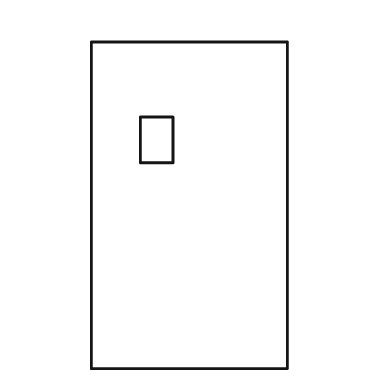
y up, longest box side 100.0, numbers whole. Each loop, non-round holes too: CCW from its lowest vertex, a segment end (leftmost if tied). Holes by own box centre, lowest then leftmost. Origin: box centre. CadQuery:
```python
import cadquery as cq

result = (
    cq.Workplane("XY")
    .moveTo(-30.0, -50.0)
    .lineTo(30.0, -50.0)
    .lineTo(30.0, 50.0)
    .lineTo(-30.0, 50.0)
    .close()
    .moveTo(-15.0, 13.0)
    .lineTo(-5.0, 13.0)
    .lineTo(-5.0, 27.0)
    .lineTo(-15.0, 27.0)
    .close()
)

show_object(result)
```